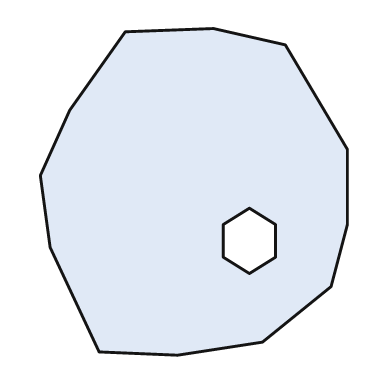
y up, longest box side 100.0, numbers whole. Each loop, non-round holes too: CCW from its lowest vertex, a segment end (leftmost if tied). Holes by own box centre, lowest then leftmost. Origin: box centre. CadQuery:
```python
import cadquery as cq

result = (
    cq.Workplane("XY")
    .moveTo(-5.0, -50.0)
    .lineTo(21.0, -46.0)
    .lineTo(42.0, -29.0)
    .lineTo(47.0, -10.0)
    .lineTo(47.0, 13.0)
    .lineTo(28.0, 45.0)
    .lineTo(6.0, 50.0)
    .lineTo(-21.0, 49.0)
    .lineTo(-38.0, 25.0)
    .lineTo(-47.0, 5.0)
    .lineTo(-44.0, -17.0)
    .lineTo(-29.0, -49.0)
    .close()
    .moveTo(17.0, -25.0)
    .lineTo(25.0, -20.0)
    .lineTo(25.0, -10.0)
    .lineTo(17.0, -5.0)
    .lineTo(9.0, -10.0)
    .lineTo(9.0, -20.0)
    .close()
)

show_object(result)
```